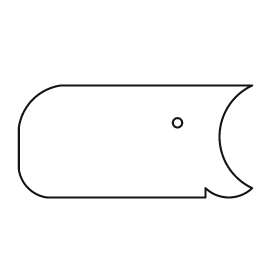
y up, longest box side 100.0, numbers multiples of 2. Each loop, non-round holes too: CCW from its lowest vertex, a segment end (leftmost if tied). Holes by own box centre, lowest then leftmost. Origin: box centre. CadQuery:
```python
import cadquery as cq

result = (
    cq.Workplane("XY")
    .moveTo(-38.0, -24.0)
    .lineTo(30.0, -24.0)
    .lineTo(30.0, -20.0)
    .threePointArc((40.0, -24.0), (50.0, -20.0))
    .threePointArc((36.0, 2.0), (50.0, 24.0))
    .lineTo(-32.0, 24.0)
    .threePointArc((-44.0, 18.0), (-50.0, 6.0))
    .lineTo(-50.0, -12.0)
    .threePointArc((-46.0, -20.0), (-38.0, -24.0))
    .close()
    .moveTo(18.0, 8.0)
    .circle(2.0)
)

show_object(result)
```